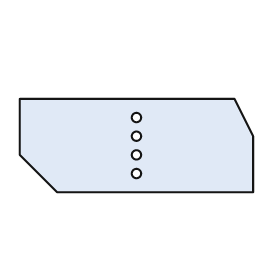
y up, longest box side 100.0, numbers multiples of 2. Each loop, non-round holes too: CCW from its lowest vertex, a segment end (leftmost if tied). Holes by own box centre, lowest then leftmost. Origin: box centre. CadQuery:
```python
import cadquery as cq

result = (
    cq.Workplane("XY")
    .moveTo(-34.0, -20.0)
    .lineTo(50.0, -20.0)
    .lineTo(50.0, 4.0)
    .lineTo(42.0, 20.0)
    .lineTo(-50.0, 20.0)
    .lineTo(-50.0, -4.0)
    .close()
    .moveTo(0.0, -12.0)
    .circle(2.0)
    .moveTo(0.0, -4.0)
    .circle(2.0)
    .moveTo(0.0, 4.0)
    .circle(2.0)
    .moveTo(0.0, 12.0)
    .circle(2.0)
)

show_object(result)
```